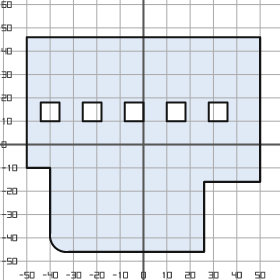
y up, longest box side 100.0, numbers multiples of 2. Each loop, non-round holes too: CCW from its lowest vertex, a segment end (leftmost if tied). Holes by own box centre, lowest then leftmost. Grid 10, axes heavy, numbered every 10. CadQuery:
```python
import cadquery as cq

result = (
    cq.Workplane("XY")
    .moveTo(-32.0, -46.0)
    .lineTo(26.0, -46.0)
    .lineTo(26.0, -16.0)
    .lineTo(50.0, -16.0)
    .lineTo(50.0, 46.0)
    .lineTo(-50.0, 46.0)
    .lineTo(-50.0, -10.0)
    .lineTo(-40.0, -10.0)
    .lineTo(-40.0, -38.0)
    .threePointArc((-38.0, -44.0), (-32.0, -46.0))
    .close()
    .moveTo(-44.0, 10.0)
    .lineTo(-36.0, 10.0)
    .lineTo(-36.0, 18.0)
    .lineTo(-44.0, 18.0)
    .close()
    .moveTo(-26.0, 10.0)
    .lineTo(-18.0, 10.0)
    .lineTo(-18.0, 18.0)
    .lineTo(-26.0, 18.0)
    .close()
    .moveTo(-8.0, 10.0)
    .lineTo(0.0, 10.0)
    .lineTo(0.0, 18.0)
    .lineTo(-8.0, 18.0)
    .close()
    .moveTo(10.0, 10.0)
    .lineTo(18.0, 10.0)
    .lineTo(18.0, 18.0)
    .lineTo(10.0, 18.0)
    .close()
    .moveTo(28.0, 10.0)
    .lineTo(36.0, 10.0)
    .lineTo(36.0, 18.0)
    .lineTo(28.0, 18.0)
    .close()
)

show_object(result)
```